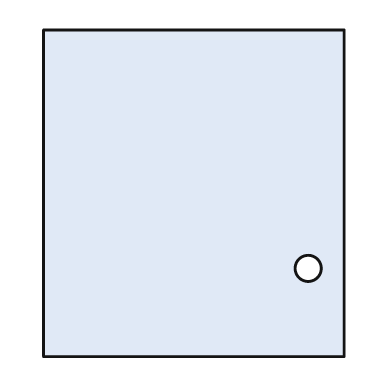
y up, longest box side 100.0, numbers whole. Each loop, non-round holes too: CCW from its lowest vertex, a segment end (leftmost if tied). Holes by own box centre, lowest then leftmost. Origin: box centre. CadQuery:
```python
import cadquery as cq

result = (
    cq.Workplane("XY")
    .moveTo(-46.0, -50.0)
    .lineTo(46.0, -50.0)
    .lineTo(46.0, 50.0)
    .lineTo(-46.0, 50.0)
    .close()
    .moveTo(35.0, -23.0)
    .circle(4.0)
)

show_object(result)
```